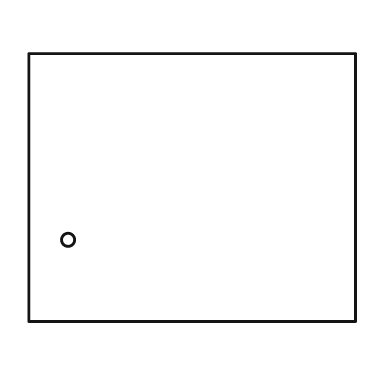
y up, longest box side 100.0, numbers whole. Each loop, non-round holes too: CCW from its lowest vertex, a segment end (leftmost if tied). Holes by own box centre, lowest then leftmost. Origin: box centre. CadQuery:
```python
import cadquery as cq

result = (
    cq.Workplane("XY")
    .moveTo(-50.0, -41.0)
    .lineTo(50.0, -41.0)
    .lineTo(50.0, 41.0)
    .lineTo(-50.0, 41.0)
    .close()
    .moveTo(-38.0, -16.0)
    .circle(2.0)
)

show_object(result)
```